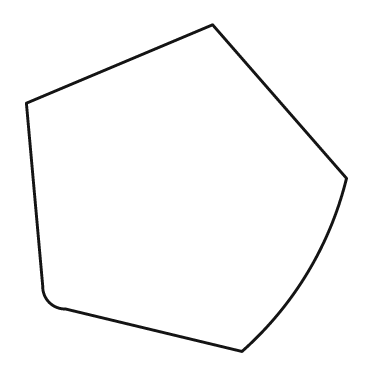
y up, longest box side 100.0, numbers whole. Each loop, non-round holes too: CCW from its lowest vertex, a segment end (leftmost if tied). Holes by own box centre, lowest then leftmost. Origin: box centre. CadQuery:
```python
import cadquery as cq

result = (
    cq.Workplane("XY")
    .moveTo(17.0, -50.0)
    .threePointArc((37.0, -26.0), (49.0, 3.0))
    .lineTo(8.0, 50.0)
    .lineTo(-49.0, 26.0)
    .lineTo(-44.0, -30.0)
    .threePointArc((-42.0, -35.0), (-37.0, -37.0))
    .close()
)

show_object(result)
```